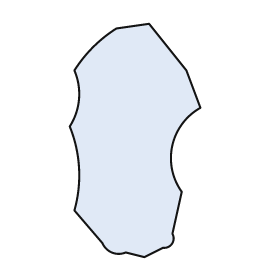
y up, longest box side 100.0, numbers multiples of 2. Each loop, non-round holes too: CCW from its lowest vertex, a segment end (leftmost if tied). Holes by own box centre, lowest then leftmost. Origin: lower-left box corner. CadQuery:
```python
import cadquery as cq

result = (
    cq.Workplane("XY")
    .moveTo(32.0, 0.0)
    .lineTo(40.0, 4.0)
    .threePointArc((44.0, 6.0), (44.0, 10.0))
    .lineTo(48.0, 28.0)
    .threePointArc((44.0, 48.0), (56.0, 64.0))
    .lineTo(50.0, 80.0)
    .lineTo(34.0, 100.0)
    .lineTo(20.0, 98.0)
    .threePointArc((10.0, 90.0), (2.0, 80.0))
    .threePointArc((4.0, 68.0), (0.0, 56.0))
    .threePointArc((4.0, 38.0), (2.0, 20.0))
    .lineTo(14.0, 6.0)
    .threePointArc((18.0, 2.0), (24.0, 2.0))
    .close()
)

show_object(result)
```